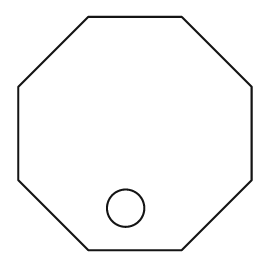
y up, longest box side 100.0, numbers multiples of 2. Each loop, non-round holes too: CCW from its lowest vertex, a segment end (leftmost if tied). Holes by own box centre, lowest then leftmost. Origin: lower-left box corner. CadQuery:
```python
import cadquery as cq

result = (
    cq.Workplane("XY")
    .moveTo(30.0, 0.0)
    .lineTo(70.0, 0.0)
    .lineTo(100.0, 30.0)
    .lineTo(100.0, 70.0)
    .lineTo(70.0, 100.0)
    .lineTo(30.0, 100.0)
    .lineTo(0.0, 70.0)
    .lineTo(0.0, 30.0)
    .close()
    .moveTo(46.0, 18.0)
    .circle(8.0)
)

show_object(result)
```